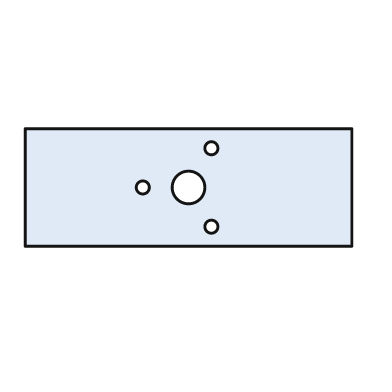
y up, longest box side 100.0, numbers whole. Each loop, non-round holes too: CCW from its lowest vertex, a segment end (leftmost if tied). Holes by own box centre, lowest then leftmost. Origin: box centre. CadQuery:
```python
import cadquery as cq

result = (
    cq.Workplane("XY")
    .moveTo(-50.0, -18.0)
    .lineTo(50.0, -18.0)
    .lineTo(50.0, 18.0)
    .lineTo(-50.0, 18.0)
    .close()
    .moveTo(7.0, -12.0)
    .circle(2.0)
    .moveTo(-14.0, 0.0)
    .circle(2.0)
    .moveTo(0.0, 0.0)
    .circle(5.0)
    .moveTo(7.0, 12.0)
    .circle(2.0)
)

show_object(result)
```